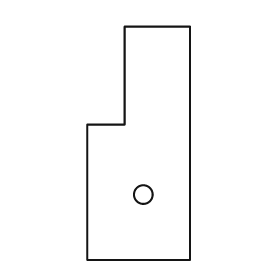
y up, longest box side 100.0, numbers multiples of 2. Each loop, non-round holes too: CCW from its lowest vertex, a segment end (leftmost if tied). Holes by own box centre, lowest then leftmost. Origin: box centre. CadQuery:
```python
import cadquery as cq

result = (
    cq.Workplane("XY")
    .moveTo(-22.0, -50.0)
    .lineTo(22.0, -50.0)
    .lineTo(22.0, 50.0)
    .lineTo(-6.0, 50.0)
    .lineTo(-6.0, 8.0)
    .lineTo(-22.0, 8.0)
    .close()
    .moveTo(2.0, -22.0)
    .circle(4.0)
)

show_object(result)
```